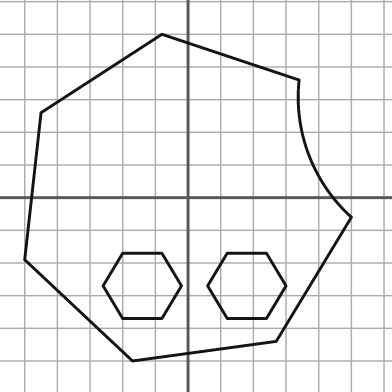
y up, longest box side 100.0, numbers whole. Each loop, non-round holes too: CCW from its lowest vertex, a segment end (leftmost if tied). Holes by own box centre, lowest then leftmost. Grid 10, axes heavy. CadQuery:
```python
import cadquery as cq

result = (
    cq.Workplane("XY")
    .moveTo(-17.0, -50.0)
    .lineTo(27.0, -44.0)
    .lineTo(50.0, -6.0)
    .threePointArc((37.0, 13.0), (34.0, 36.0))
    .lineTo(-8.0, 50.0)
    .lineTo(-45.0, 26.0)
    .lineTo(-50.0, -19.0)
    .close()
    .moveTo(-20.0, -37.0)
    .lineTo(-8.0, -37.0)
    .lineTo(-2.0, -27.0)
    .lineTo(-8.0, -17.0)
    .lineTo(-20.0, -17.0)
    .lineTo(-26.0, -27.0)
    .close()
    .moveTo(12.0, -37.0)
    .lineTo(24.0, -37.0)
    .lineTo(30.0, -27.0)
    .lineTo(24.0, -17.0)
    .lineTo(12.0, -17.0)
    .lineTo(6.0, -27.0)
    .close()
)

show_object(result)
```